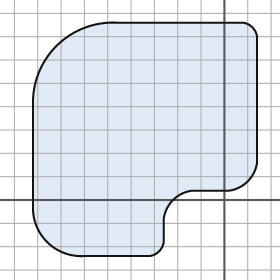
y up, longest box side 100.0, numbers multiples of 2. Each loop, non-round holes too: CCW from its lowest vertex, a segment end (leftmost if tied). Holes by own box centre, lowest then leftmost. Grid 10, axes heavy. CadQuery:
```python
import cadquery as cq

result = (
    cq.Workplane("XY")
    .moveTo(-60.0, -24.0)
    .lineTo(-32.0, -24.0)
    .threePointArc((-28.0, -22.0), (-26.0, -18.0))
    .lineTo(-26.0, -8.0)
    .threePointArc((-22.0, 0.0), (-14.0, 4.0))
    .lineTo(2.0, 4.0)
    .threePointArc((10.0, 8.0), (14.0, 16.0))
    .lineTo(14.0, 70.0)
    .threePointArc((12.0, 74.0), (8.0, 76.0))
    .lineTo(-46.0, 76.0)
    .threePointArc((-72.0, 66.0), (-82.0, 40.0))
    .lineTo(-82.0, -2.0)
    .threePointArc((-76.0, -18.0), (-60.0, -24.0))
    .close()
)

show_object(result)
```